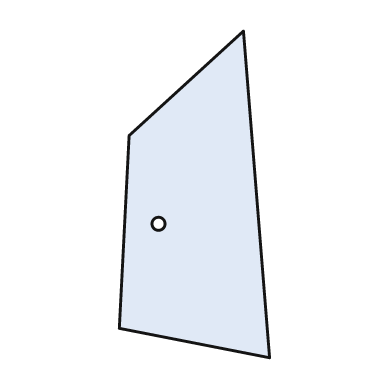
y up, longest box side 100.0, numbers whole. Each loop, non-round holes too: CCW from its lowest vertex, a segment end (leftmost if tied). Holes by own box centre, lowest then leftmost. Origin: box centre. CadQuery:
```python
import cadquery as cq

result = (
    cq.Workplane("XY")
    .moveTo(23.0, -50.0)
    .lineTo(15.0, 50.0)
    .lineTo(-20.0, 18.0)
    .lineTo(-23.0, -41.0)
    .close()
    .moveTo(-11.0, -9.0)
    .circle(2.0)
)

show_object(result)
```